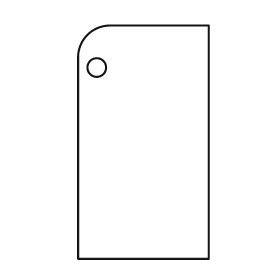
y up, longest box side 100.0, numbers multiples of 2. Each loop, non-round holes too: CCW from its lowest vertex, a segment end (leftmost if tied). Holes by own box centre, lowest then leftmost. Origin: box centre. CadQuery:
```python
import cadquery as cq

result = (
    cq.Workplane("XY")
    .moveTo(-28.0, -50.0)
    .lineTo(28.0, -50.0)
    .lineTo(28.0, 50.0)
    .lineTo(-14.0, 50.0)
    .threePointArc((-24.0, 46.0), (-28.0, 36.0))
    .close()
    .moveTo(-20.0, 32.0)
    .circle(4.0)
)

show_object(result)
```